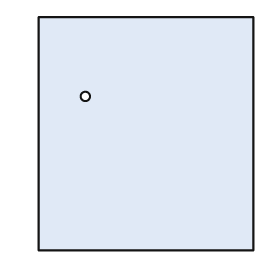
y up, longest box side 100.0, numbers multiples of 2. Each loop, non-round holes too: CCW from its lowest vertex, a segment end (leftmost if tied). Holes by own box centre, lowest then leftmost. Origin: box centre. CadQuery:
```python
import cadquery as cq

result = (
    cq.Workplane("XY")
    .moveTo(-46.0, -50.0)
    .lineTo(46.0, -50.0)
    .lineTo(46.0, 50.0)
    .lineTo(-46.0, 50.0)
    .close()
    .moveTo(-26.0, 16.0)
    .circle(2.0)
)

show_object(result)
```